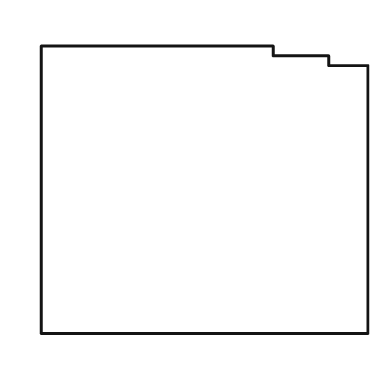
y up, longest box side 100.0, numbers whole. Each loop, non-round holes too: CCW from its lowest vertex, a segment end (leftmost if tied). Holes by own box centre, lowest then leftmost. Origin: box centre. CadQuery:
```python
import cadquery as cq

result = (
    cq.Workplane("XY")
    .moveTo(-50.0, -44.0)
    .lineTo(50.0, -44.0)
    .lineTo(50.0, 38.0)
    .lineTo(38.0, 38.0)
    .lineTo(38.0, 41.0)
    .lineTo(21.0, 41.0)
    .lineTo(21.0, 44.0)
    .lineTo(-50.0, 44.0)
    .close()
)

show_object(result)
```